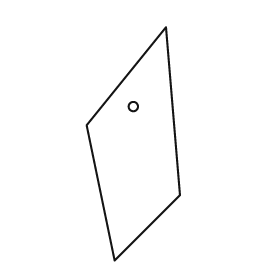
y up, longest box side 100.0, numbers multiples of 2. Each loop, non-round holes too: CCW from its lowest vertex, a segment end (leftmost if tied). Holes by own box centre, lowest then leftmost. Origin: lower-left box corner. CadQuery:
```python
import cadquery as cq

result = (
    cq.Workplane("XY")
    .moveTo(12.0, 0.0)
    .lineTo(40.0, 28.0)
    .lineTo(34.0, 100.0)
    .lineTo(0.0, 58.0)
    .close()
    .moveTo(20.0, 66.0)
    .circle(2.0)
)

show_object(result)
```